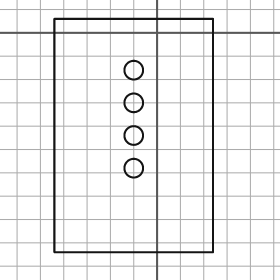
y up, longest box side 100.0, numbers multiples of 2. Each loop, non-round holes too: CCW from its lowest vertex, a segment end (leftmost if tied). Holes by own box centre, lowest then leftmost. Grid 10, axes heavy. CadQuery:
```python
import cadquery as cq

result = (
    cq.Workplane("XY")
    .moveTo(-44.0, -94.0)
    .lineTo(24.0, -94.0)
    .lineTo(24.0, 6.0)
    .lineTo(-44.0, 6.0)
    .close()
    .moveTo(-10.0, -58.0)
    .circle(4.0)
    .moveTo(-10.0, -44.0)
    .circle(4.0)
    .moveTo(-10.0, -30.0)
    .circle(4.0)
    .moveTo(-10.0, -16.0)
    .circle(4.0)
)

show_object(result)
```